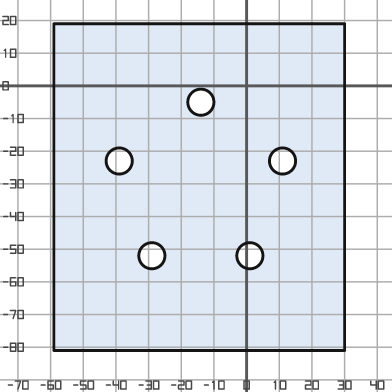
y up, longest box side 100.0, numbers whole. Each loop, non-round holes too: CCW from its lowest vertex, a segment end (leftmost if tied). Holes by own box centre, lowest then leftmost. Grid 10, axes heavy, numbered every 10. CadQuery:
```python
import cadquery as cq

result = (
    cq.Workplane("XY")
    .moveTo(-59.0, -81.0)
    .lineTo(30.0, -81.0)
    .lineTo(30.0, 19.0)
    .lineTo(-59.0, 19.0)
    .close()
    .moveTo(-29.0, -52.0)
    .circle(4.0)
    .moveTo(1.0, -52.0)
    .circle(4.0)
    .moveTo(-39.0, -23.0)
    .circle(4.0)
    .moveTo(11.0, -23.0)
    .circle(4.0)
    .moveTo(-14.0, -5.0)
    .circle(4.0)
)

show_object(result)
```